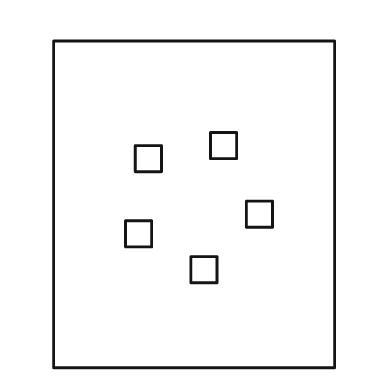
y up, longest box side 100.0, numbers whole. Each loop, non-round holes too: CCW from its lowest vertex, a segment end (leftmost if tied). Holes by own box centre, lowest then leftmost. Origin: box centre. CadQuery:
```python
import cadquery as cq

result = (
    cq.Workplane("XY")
    .moveTo(-43.0, -50.0)
    .lineTo(43.0, -50.0)
    .lineTo(43.0, 50.0)
    .lineTo(-43.0, 50.0)
    .close()
    .moveTo(-1.0, -24.0)
    .lineTo(7.0, -24.0)
    .lineTo(7.0, -16.0)
    .lineTo(-1.0, -16.0)
    .close()
    .moveTo(-21.0, -13.0)
    .lineTo(-13.0, -13.0)
    .lineTo(-13.0, -5.0)
    .lineTo(-21.0, -5.0)
    .close()
    .moveTo(16.0, -7.0)
    .lineTo(24.0, -7.0)
    .lineTo(24.0, 1.0)
    .lineTo(16.0, 1.0)
    .close()
    .moveTo(-18.0, 10.0)
    .lineTo(-10.0, 10.0)
    .lineTo(-10.0, 18.0)
    .lineTo(-18.0, 18.0)
    .close()
    .moveTo(5.0, 14.0)
    .lineTo(13.0, 14.0)
    .lineTo(13.0, 22.0)
    .lineTo(5.0, 22.0)
    .close()
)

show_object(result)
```